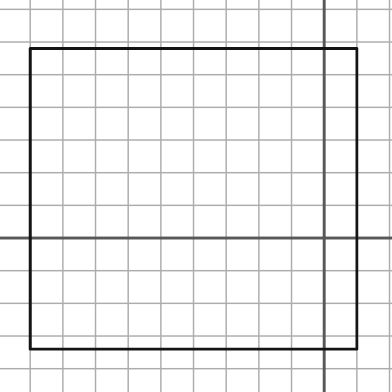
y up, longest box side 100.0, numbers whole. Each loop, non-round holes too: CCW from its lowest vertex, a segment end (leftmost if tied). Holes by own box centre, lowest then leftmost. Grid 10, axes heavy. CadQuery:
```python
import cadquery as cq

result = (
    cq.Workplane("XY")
    .moveTo(-90.0, -34.0)
    .lineTo(10.0, -34.0)
    .lineTo(10.0, 58.0)
    .lineTo(-90.0, 58.0)
    .close()
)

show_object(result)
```